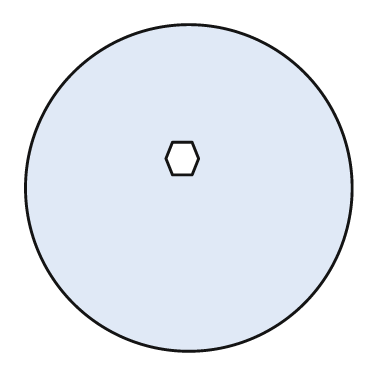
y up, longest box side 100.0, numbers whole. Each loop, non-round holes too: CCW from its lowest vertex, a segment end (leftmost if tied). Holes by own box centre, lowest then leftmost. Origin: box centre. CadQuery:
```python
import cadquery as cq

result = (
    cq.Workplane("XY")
    .moveTo(0.0, 0.0)
    .circle(50.0)
    .moveTo(-5.0, 4.0)
    .lineTo(1.0, 4.0)
    .lineTo(3.0, 9.0)
    .lineTo(1.0, 14.0)
    .lineTo(-5.0, 14.0)
    .lineTo(-7.0, 9.0)
    .close()
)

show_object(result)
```